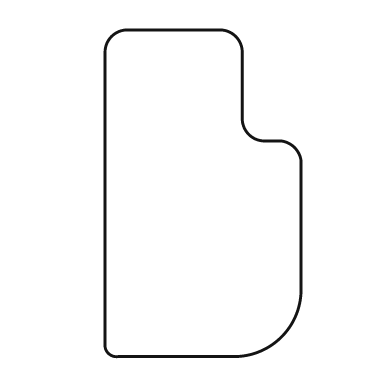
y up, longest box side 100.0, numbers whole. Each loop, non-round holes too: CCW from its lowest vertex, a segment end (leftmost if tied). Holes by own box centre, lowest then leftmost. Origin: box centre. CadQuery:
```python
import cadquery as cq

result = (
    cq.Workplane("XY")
    .moveTo(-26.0, -50.0)
    .lineTo(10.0, -50.0)
    .threePointArc((24.0, -44.0), (30.0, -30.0))
    .lineTo(30.0, 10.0)
    .threePointArc((28.0, 14.0), (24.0, 16.0))
    .lineTo(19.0, 16.0)
    .threePointArc((14.0, 18.0), (12.0, 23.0))
    .lineTo(12.0, 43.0)
    .threePointArc((10.0, 48.0), (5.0, 50.0))
    .lineTo(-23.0, 50.0)
    .threePointArc((-28.0, 48.0), (-30.0, 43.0))
    .lineTo(-30.0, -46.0)
    .threePointArc((-29.0, -49.0), (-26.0, -50.0))
    .close()
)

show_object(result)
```